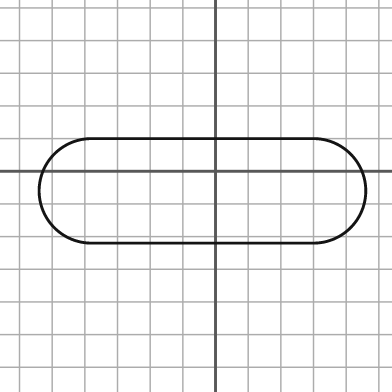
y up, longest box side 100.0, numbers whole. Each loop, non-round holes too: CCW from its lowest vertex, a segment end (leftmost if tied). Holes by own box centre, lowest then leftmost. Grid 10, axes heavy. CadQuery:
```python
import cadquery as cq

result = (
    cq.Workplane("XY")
    .moveTo(-38.0, -22.0)
    .lineTo(30.0, -22.0)
    .threePointArc((46.0, -6.0), (30.0, 10.0))
    .lineTo(-38.0, 10.0)
    .threePointArc((-54.0, -6.0), (-38.0, -22.0))
    .close()
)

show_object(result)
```